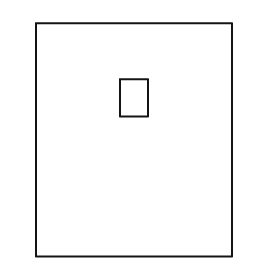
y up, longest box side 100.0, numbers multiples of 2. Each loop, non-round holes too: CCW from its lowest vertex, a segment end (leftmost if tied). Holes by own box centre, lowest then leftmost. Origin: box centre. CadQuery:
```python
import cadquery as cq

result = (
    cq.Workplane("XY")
    .moveTo(-42.0, -50.0)
    .lineTo(42.0, -50.0)
    .lineTo(42.0, 50.0)
    .lineTo(-42.0, 50.0)
    .close()
    .moveTo(-6.0, 10.0)
    .lineTo(6.0, 10.0)
    .lineTo(6.0, 26.0)
    .lineTo(-6.0, 26.0)
    .close()
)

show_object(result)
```